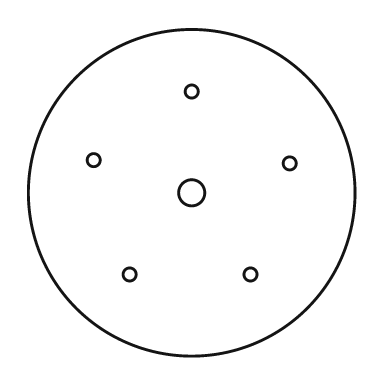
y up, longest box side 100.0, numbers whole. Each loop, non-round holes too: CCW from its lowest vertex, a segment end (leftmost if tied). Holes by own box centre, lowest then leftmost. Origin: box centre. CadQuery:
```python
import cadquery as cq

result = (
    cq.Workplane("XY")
    .moveTo(0.0, 0.0)
    .circle(50.0)
    .moveTo(-19.0, -25.0)
    .circle(2.0)
    .moveTo(18.0, -25.0)
    .circle(2.0)
    .moveTo(0.0, 0.0)
    .circle(4.0)
    .moveTo(30.0, 9.0)
    .circle(2.0)
    .moveTo(-30.0, 10.0)
    .circle(2.0)
    .moveTo(0.0, 31.0)
    .circle(2.0)
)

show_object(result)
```